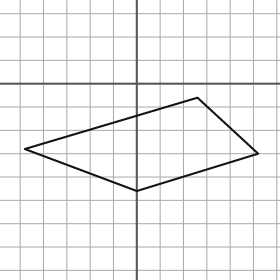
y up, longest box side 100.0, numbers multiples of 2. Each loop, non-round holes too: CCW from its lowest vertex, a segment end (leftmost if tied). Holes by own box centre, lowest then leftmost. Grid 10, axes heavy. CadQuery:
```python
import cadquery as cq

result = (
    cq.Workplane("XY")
    .moveTo(0.0, -46.0)
    .lineTo(52.0, -30.0)
    .lineTo(26.0, -6.0)
    .lineTo(-48.0, -28.0)
    .close()
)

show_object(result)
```